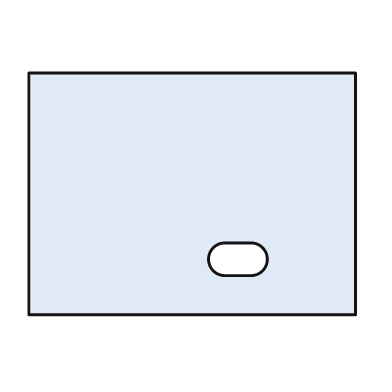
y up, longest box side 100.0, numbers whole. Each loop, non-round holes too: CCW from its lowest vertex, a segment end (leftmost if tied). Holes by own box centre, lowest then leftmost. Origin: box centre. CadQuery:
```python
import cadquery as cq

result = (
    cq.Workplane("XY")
    .moveTo(-50.0, -37.0)
    .lineTo(50.0, -37.0)
    .lineTo(50.0, 37.0)
    .lineTo(-50.0, 37.0)
    .close()
    .moveTo(10.0, -25.0)
    .lineTo(18.0, -25.0)
    .threePointArc((23.0, -20.0), (18.0, -15.0))
    .lineTo(10.0, -15.0)
    .threePointArc((5.0, -20.0), (10.0, -25.0))
    .close()
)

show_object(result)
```